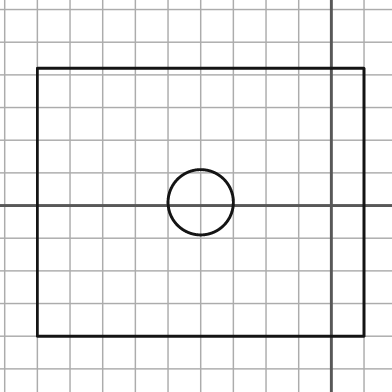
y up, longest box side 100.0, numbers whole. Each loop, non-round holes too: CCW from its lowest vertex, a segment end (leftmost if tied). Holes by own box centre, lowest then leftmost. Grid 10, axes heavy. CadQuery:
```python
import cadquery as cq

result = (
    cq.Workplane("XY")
    .moveTo(-90.0, -40.0)
    .lineTo(10.0, -40.0)
    .lineTo(10.0, 42.0)
    .lineTo(-90.0, 42.0)
    .close()
    .moveTo(-40.0, 1.0)
    .circle(10.0)
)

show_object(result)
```